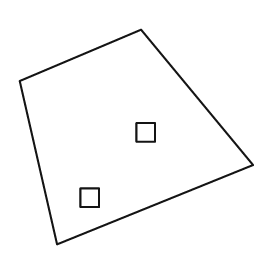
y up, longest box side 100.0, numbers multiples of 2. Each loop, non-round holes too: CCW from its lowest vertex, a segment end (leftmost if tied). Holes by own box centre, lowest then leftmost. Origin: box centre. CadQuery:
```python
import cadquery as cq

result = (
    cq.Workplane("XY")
    .moveTo(-34.0, -46.0)
    .lineTo(50.0, -12.0)
    .lineTo(2.0, 46.0)
    .lineTo(-50.0, 24.0)
    .close()
    .moveTo(-24.0, -30.0)
    .lineTo(-16.0, -30.0)
    .lineTo(-16.0, -22.0)
    .lineTo(-24.0, -22.0)
    .close()
    .moveTo(0.0, -2.0)
    .lineTo(8.0, -2.0)
    .lineTo(8.0, 6.0)
    .lineTo(0.0, 6.0)
    .close()
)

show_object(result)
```